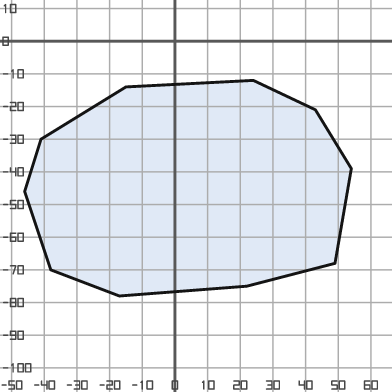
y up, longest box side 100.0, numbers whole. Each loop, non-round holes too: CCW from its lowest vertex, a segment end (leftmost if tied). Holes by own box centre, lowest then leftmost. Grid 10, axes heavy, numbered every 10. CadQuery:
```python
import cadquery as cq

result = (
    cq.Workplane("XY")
    .moveTo(-17.0, -78.0)
    .lineTo(22.0, -75.0)
    .lineTo(49.0, -68.0)
    .lineTo(54.0, -39.0)
    .lineTo(43.0, -21.0)
    .lineTo(24.0, -12.0)
    .lineTo(-15.0, -14.0)
    .lineTo(-41.0, -30.0)
    .lineTo(-46.0, -46.0)
    .lineTo(-38.0, -70.0)
    .close()
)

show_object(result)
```